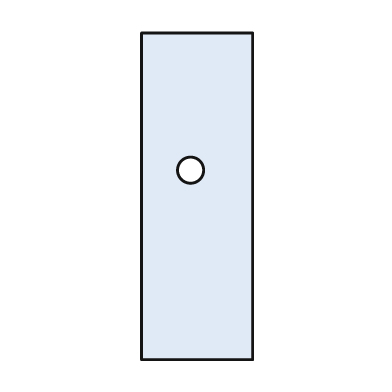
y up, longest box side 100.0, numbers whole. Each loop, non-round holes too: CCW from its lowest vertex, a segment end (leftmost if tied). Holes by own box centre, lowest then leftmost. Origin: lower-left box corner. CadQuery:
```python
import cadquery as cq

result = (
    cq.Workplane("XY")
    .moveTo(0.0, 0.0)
    .lineTo(34.0, 0.0)
    .lineTo(34.0, 100.0)
    .lineTo(0.0, 100.0)
    .close()
    .moveTo(15.0, 58.0)
    .circle(4.0)
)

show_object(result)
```